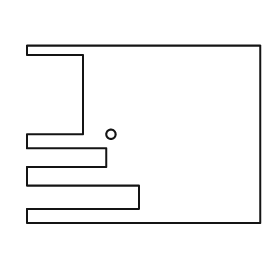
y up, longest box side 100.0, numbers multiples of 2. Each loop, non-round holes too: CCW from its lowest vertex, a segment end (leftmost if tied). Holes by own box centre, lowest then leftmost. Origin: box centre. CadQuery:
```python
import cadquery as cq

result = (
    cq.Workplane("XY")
    .moveTo(-50.0, -38.0)
    .lineTo(50.0, -38.0)
    .lineTo(50.0, 38.0)
    .lineTo(-50.0, 38.0)
    .lineTo(-50.0, 34.0)
    .lineTo(-26.0, 34.0)
    .lineTo(-26.0, 0.0)
    .lineTo(-50.0, 0.0)
    .lineTo(-50.0, -6.0)
    .lineTo(-16.0, -6.0)
    .lineTo(-16.0, -14.0)
    .lineTo(-50.0, -14.0)
    .lineTo(-50.0, -22.0)
    .lineTo(-2.0, -22.0)
    .lineTo(-2.0, -32.0)
    .lineTo(-50.0, -32.0)
    .close()
    .moveTo(-14.0, 0.0)
    .circle(2.0)
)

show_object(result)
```